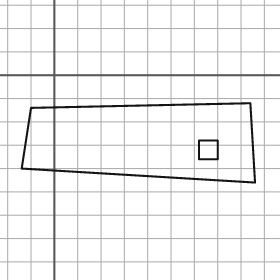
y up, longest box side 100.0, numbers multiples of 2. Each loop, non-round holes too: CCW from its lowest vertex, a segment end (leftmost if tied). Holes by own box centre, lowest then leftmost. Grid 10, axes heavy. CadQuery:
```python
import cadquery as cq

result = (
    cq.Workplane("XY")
    .moveTo(86.0, -46.0)
    .lineTo(84.0, -12.0)
    .lineTo(-10.0, -14.0)
    .lineTo(-14.0, -40.0)
    .close()
    .moveTo(62.0, -36.0)
    .lineTo(70.0, -36.0)
    .lineTo(70.0, -28.0)
    .lineTo(62.0, -28.0)
    .close()
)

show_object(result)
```